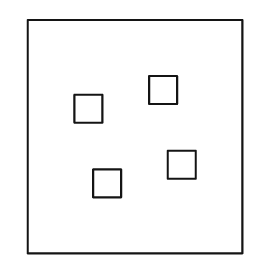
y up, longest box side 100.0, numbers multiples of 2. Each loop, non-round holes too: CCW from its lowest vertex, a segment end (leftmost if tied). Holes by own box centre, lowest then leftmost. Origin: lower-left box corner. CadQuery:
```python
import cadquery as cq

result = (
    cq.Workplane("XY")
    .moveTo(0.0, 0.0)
    .lineTo(92.0, 0.0)
    .lineTo(92.0, 100.0)
    .lineTo(0.0, 100.0)
    .close()
    .moveTo(28.0, 24.0)
    .lineTo(40.0, 24.0)
    .lineTo(40.0, 36.0)
    .lineTo(28.0, 36.0)
    .close()
    .moveTo(60.0, 32.0)
    .lineTo(72.0, 32.0)
    .lineTo(72.0, 44.0)
    .lineTo(60.0, 44.0)
    .close()
    .moveTo(20.0, 56.0)
    .lineTo(32.0, 56.0)
    .lineTo(32.0, 68.0)
    .lineTo(20.0, 68.0)
    .close()
    .moveTo(52.0, 64.0)
    .lineTo(64.0, 64.0)
    .lineTo(64.0, 76.0)
    .lineTo(52.0, 76.0)
    .close()
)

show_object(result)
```